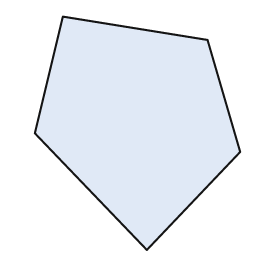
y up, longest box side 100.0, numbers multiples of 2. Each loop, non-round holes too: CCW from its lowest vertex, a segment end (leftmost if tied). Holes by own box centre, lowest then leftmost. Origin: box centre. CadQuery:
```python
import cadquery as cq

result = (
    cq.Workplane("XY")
    .moveTo(4.0, -50.0)
    .lineTo(44.0, -8.0)
    .lineTo(30.0, 40.0)
    .lineTo(-32.0, 50.0)
    .lineTo(-44.0, 0.0)
    .close()
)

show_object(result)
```